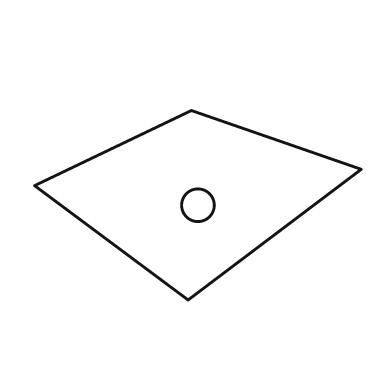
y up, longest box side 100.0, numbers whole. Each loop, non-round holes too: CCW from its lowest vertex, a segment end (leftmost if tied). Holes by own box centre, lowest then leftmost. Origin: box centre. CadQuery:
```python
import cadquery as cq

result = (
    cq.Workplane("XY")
    .moveTo(-3.0, -29.0)
    .lineTo(50.0, 11.0)
    .lineTo(-2.0, 29.0)
    .lineTo(-50.0, 6.0)
    .close()
    .moveTo(0.0, 0.0)
    .circle(5.0)
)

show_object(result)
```